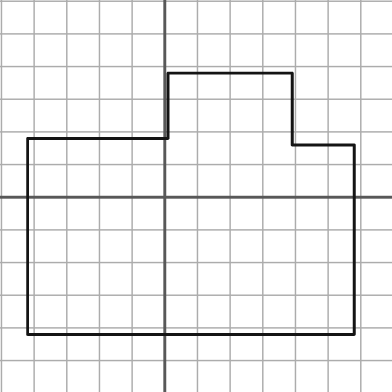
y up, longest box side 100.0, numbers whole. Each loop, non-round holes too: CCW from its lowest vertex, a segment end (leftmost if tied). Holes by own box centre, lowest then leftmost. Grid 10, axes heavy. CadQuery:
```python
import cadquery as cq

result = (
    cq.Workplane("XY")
    .moveTo(-42.0, -42.0)
    .lineTo(58.0, -42.0)
    .lineTo(58.0, 16.0)
    .lineTo(39.0, 16.0)
    .lineTo(39.0, 38.0)
    .lineTo(1.0, 38.0)
    .lineTo(1.0, 18.0)
    .lineTo(-42.0, 18.0)
    .close()
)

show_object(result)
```